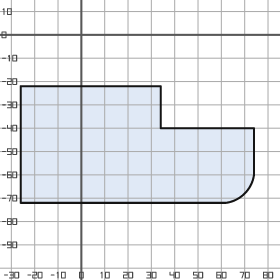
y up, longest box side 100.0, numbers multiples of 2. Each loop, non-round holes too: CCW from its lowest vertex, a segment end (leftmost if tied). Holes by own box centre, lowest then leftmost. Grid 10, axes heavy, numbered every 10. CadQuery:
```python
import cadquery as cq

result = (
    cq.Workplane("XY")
    .moveTo(-26.0, -72.0)
    .lineTo(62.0, -72.0)
    .threePointArc((70.0, -68.0), (74.0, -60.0))
    .lineTo(74.0, -40.0)
    .lineTo(34.0, -40.0)
    .lineTo(34.0, -22.0)
    .lineTo(-26.0, -22.0)
    .close()
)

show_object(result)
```